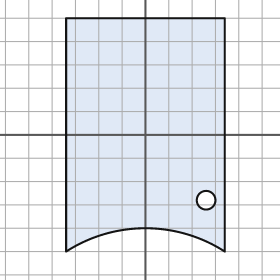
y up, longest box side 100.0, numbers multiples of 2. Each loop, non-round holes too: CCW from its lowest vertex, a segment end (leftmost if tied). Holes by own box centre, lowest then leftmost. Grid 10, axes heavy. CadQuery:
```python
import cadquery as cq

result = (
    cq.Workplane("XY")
    .moveTo(-34.0, -50.0)
    .threePointArc((0.0, -40.0), (34.0, -50.0))
    .lineTo(34.0, 50.0)
    .lineTo(-34.0, 50.0)
    .close()
    .moveTo(26.0, -28.0)
    .circle(4.0)
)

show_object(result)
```